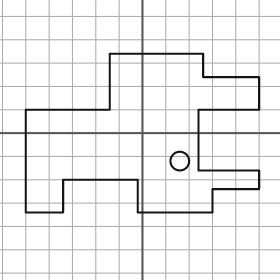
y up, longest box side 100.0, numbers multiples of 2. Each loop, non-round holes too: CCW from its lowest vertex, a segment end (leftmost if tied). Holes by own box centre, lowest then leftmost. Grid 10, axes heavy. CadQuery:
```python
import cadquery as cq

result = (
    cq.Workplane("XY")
    .moveTo(-50.0, -34.0)
    .lineTo(-34.0, -34.0)
    .lineTo(-34.0, -20.0)
    .lineTo(-2.0, -20.0)
    .lineTo(-2.0, -34.0)
    .lineTo(30.0, -34.0)
    .lineTo(30.0, -24.0)
    .lineTo(50.0, -24.0)
    .lineTo(50.0, -16.0)
    .lineTo(24.0, -16.0)
    .lineTo(24.0, 10.0)
    .lineTo(50.0, 10.0)
    .lineTo(50.0, 24.0)
    .lineTo(26.0, 24.0)
    .lineTo(26.0, 34.0)
    .lineTo(-14.0, 34.0)
    .lineTo(-14.0, 10.0)
    .lineTo(-50.0, 10.0)
    .close()
    .moveTo(16.0, -12.0)
    .circle(4.0)
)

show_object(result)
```